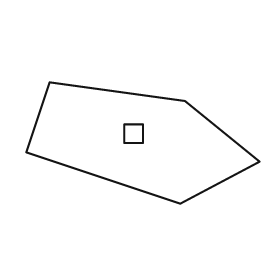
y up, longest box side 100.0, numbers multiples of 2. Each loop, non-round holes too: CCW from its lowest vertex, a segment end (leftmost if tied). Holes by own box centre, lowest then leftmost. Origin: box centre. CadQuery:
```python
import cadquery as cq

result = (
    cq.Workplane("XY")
    .moveTo(16.0, -26.0)
    .lineTo(50.0, -8.0)
    .lineTo(18.0, 18.0)
    .lineTo(-40.0, 26.0)
    .lineTo(-50.0, -4.0)
    .close()
    .moveTo(-8.0, 0.0)
    .lineTo(0.0, 0.0)
    .lineTo(0.0, 8.0)
    .lineTo(-8.0, 8.0)
    .close()
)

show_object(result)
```